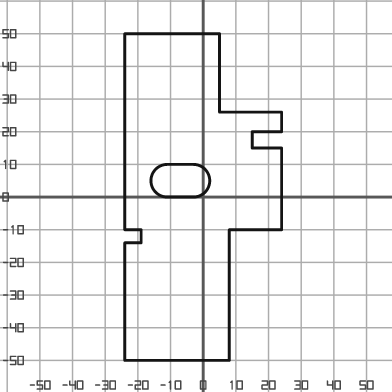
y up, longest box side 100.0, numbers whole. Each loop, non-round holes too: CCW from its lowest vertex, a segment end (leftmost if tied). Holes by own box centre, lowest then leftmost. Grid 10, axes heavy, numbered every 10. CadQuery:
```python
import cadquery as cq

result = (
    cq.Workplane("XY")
    .moveTo(-24.0, -50.0)
    .lineTo(8.0, -50.0)
    .lineTo(8.0, -10.0)
    .lineTo(24.0, -10.0)
    .lineTo(24.0, 15.0)
    .lineTo(15.0, 15.0)
    .lineTo(15.0, 20.0)
    .lineTo(24.0, 20.0)
    .lineTo(24.0, 26.0)
    .lineTo(5.0, 26.0)
    .lineTo(5.0, 50.0)
    .lineTo(-24.0, 50.0)
    .lineTo(-24.0, -10.0)
    .lineTo(-19.0, -10.0)
    .lineTo(-19.0, -14.0)
    .lineTo(-24.0, -14.0)
    .close()
    .moveTo(-11.0, 0.0)
    .lineTo(-3.0, 0.0)
    .threePointArc((2.0, 5.0), (-3.0, 10.0))
    .lineTo(-11.0, 10.0)
    .threePointArc((-16.0, 5.0), (-11.0, 0.0))
    .close()
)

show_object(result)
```